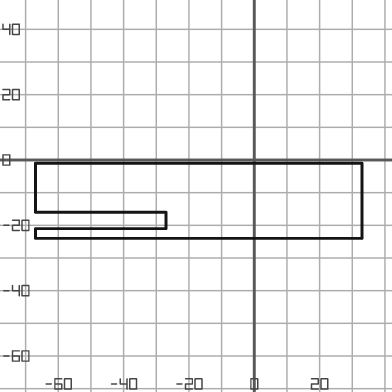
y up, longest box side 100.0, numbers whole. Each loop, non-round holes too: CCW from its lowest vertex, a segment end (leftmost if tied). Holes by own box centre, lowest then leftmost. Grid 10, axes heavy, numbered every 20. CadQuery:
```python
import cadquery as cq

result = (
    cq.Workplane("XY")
    .moveTo(-67.0, -24.0)
    .lineTo(33.0, -24.0)
    .lineTo(33.0, -1.0)
    .lineTo(-67.0, -1.0)
    .lineTo(-67.0, -16.0)
    .lineTo(-27.0, -16.0)
    .lineTo(-27.0, -21.0)
    .lineTo(-67.0, -21.0)
    .close()
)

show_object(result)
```